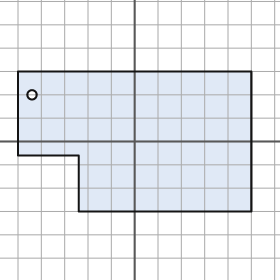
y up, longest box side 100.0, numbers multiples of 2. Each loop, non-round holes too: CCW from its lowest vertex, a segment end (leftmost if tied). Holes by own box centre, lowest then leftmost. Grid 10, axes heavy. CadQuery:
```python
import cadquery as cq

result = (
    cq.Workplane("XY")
    .moveTo(-24.0, -30.0)
    .lineTo(50.0, -30.0)
    .lineTo(50.0, 30.0)
    .lineTo(-50.0, 30.0)
    .lineTo(-50.0, -6.0)
    .lineTo(-24.0, -6.0)
    .close()
    .moveTo(-44.0, 20.0)
    .circle(2.0)
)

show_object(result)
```